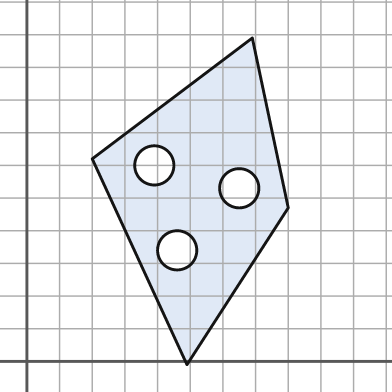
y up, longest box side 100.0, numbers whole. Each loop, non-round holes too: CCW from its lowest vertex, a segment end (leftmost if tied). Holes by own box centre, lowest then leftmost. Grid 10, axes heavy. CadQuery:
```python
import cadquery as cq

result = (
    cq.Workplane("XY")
    .moveTo(49.0, -1.0)
    .lineTo(80.0, 47.0)
    .lineTo(69.0, 99.0)
    .lineTo(20.0, 62.0)
    .close()
    .moveTo(46.0, 34.0)
    .circle(6.0)
    .moveTo(65.0, 53.0)
    .circle(6.0)
    .moveTo(39.0, 60.0)
    .circle(6.0)
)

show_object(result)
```